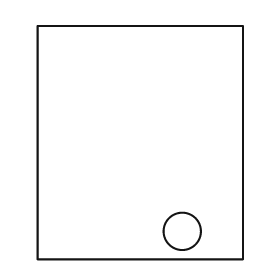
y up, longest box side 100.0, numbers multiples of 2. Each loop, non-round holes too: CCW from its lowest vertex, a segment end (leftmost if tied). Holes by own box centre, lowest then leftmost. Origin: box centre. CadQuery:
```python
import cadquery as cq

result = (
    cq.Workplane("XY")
    .moveTo(-44.0, -50.0)
    .lineTo(44.0, -50.0)
    .lineTo(44.0, 50.0)
    .lineTo(-44.0, 50.0)
    .close()
    .moveTo(18.0, -38.0)
    .circle(8.0)
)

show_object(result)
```